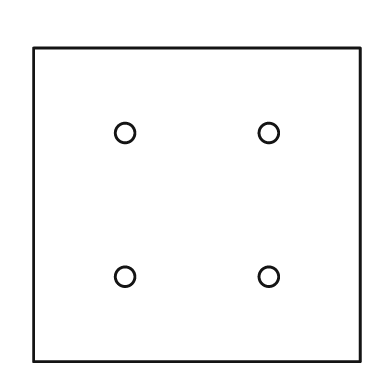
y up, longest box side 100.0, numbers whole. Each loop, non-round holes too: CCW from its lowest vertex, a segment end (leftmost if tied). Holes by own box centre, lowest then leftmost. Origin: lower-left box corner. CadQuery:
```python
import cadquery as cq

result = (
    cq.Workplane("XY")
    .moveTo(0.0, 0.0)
    .lineTo(100.0, 0.0)
    .lineTo(100.0, 96.0)
    .lineTo(0.0, 96.0)
    .close()
    .moveTo(28.0, 26.0)
    .circle(3.0)
    .moveTo(72.0, 26.0)
    .circle(3.0)
    .moveTo(28.0, 70.0)
    .circle(3.0)
    .moveTo(72.0, 70.0)
    .circle(3.0)
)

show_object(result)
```